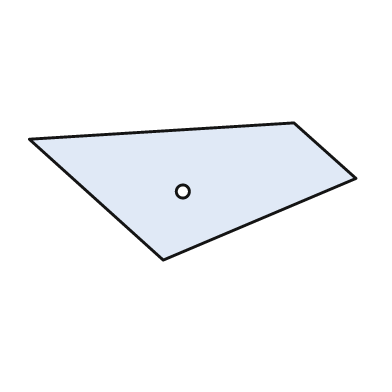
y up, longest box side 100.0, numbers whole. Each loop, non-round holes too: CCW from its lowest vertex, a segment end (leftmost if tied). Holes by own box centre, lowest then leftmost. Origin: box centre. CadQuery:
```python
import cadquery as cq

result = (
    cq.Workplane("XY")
    .moveTo(-9.0, -21.0)
    .lineTo(50.0, 4.0)
    .lineTo(31.0, 21.0)
    .lineTo(-50.0, 16.0)
    .close()
    .moveTo(-3.0, 0.0)
    .circle(2.0)
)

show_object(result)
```